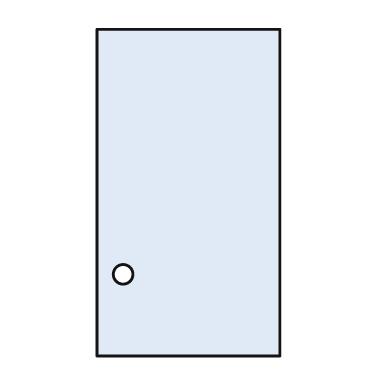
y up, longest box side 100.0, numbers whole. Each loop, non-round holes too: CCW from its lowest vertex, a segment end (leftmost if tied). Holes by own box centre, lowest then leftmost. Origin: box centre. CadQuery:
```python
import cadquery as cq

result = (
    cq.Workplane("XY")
    .moveTo(-28.0, -50.0)
    .lineTo(28.0, -50.0)
    .lineTo(28.0, 50.0)
    .lineTo(-28.0, 50.0)
    .close()
    .moveTo(-20.0, -25.0)
    .circle(3.0)
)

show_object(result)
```